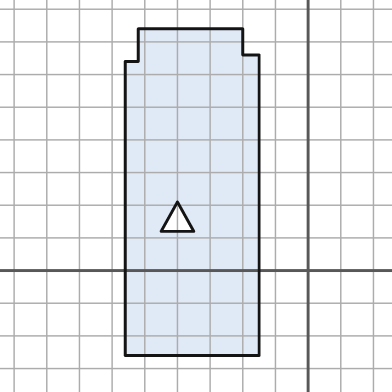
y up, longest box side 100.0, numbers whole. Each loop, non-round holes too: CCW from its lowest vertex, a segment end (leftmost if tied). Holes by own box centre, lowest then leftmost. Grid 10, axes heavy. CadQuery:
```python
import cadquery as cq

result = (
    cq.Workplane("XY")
    .moveTo(-56.0, -26.0)
    .lineTo(-15.0, -26.0)
    .lineTo(-15.0, 66.0)
    .lineTo(-20.0, 66.0)
    .lineTo(-20.0, 74.0)
    .lineTo(-52.0, 74.0)
    .lineTo(-52.0, 64.0)
    .lineTo(-56.0, 64.0)
    .close()
    .moveTo(-45.0, 12.0)
    .lineTo(-35.0, 12.0)
    .lineTo(-40.0, 21.0)
    .close()
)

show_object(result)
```